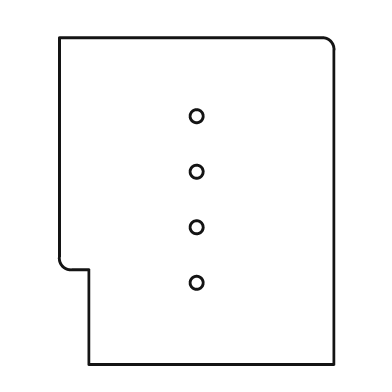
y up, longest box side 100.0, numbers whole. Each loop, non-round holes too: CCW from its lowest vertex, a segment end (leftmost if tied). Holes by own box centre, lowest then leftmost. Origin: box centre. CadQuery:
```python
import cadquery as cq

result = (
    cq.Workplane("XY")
    .moveTo(-33.0, -50.0)
    .lineTo(42.0, -50.0)
    .lineTo(42.0, 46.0)
    .threePointArc((41.0, 49.0), (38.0, 50.0))
    .lineTo(-42.0, 50.0)
    .lineTo(-42.0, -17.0)
    .threePointArc((-41.0, -20.0), (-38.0, -21.0))
    .lineTo(-33.0, -21.0)
    .close()
    .moveTo(0.0, -25.0)
    .circle(2.0)
    .moveTo(0.0, -8.0)
    .circle(2.0)
    .moveTo(0.0, 9.0)
    .circle(2.0)
    .moveTo(0.0, 26.0)
    .circle(2.0)
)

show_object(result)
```